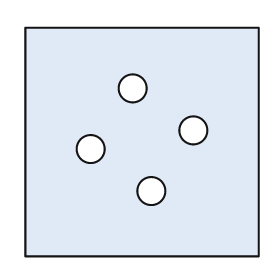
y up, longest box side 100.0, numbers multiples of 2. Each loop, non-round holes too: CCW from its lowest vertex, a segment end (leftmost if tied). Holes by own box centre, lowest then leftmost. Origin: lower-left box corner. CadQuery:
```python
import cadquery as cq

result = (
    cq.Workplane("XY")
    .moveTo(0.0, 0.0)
    .lineTo(100.0, 0.0)
    .lineTo(100.0, 98.0)
    .lineTo(0.0, 98.0)
    .close()
    .moveTo(54.0, 28.0)
    .circle(6.0)
    .moveTo(28.0, 46.0)
    .circle(6.0)
    .moveTo(72.0, 54.0)
    .circle(6.0)
    .moveTo(46.0, 72.0)
    .circle(6.0)
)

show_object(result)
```